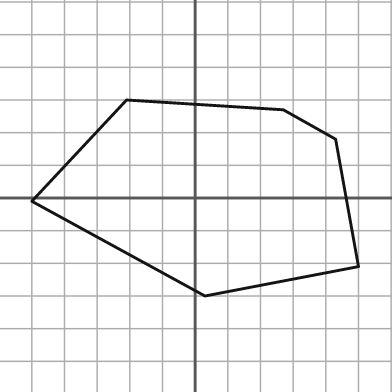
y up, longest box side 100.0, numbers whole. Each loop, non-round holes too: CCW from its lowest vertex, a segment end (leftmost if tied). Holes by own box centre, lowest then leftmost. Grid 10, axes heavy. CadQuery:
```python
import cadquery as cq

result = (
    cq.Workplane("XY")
    .moveTo(3.0, -30.0)
    .lineTo(50.0, -21.0)
    .lineTo(43.0, 18.0)
    .lineTo(27.0, 27.0)
    .lineTo(-21.0, 30.0)
    .lineTo(-50.0, -1.0)
    .close()
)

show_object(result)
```